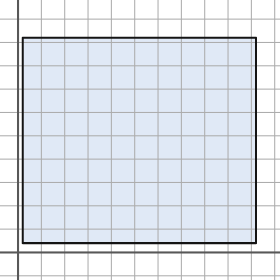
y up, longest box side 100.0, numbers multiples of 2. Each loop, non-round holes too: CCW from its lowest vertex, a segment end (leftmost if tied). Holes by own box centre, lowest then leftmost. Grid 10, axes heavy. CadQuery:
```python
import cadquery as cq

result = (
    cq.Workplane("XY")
    .moveTo(2.0, 4.0)
    .lineTo(102.0, 4.0)
    .lineTo(102.0, 92.0)
    .lineTo(2.0, 92.0)
    .close()
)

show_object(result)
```